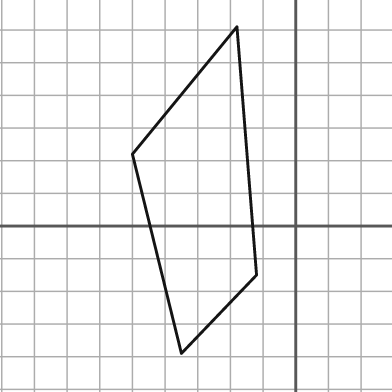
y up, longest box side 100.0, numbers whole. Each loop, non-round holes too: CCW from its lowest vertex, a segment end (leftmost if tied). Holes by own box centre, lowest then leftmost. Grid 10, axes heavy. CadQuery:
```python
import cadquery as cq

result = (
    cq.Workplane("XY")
    .moveTo(-35.0, -39.0)
    .lineTo(-12.0, -15.0)
    .lineTo(-18.0, 61.0)
    .lineTo(-50.0, 22.0)
    .close()
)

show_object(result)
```